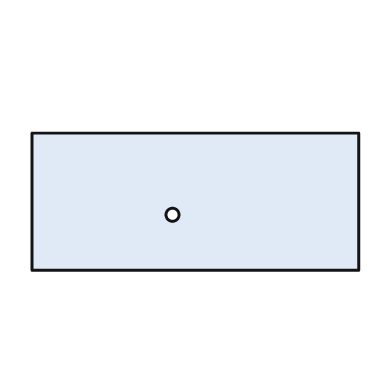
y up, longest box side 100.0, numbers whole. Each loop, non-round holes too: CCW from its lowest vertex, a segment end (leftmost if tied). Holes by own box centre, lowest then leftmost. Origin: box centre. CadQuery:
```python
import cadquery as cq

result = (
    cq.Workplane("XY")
    .moveTo(-50.0, -21.0)
    .lineTo(50.0, -21.0)
    .lineTo(50.0, 21.0)
    .lineTo(-50.0, 21.0)
    .close()
    .moveTo(-7.0, -4.0)
    .circle(2.0)
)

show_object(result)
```